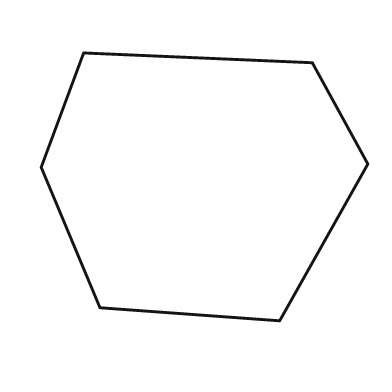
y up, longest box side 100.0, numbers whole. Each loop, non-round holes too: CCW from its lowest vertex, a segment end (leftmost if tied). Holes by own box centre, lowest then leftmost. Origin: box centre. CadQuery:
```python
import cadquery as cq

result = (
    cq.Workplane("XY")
    .moveTo(23.0, -41.0)
    .lineTo(50.0, 7.0)
    .lineTo(33.0, 38.0)
    .lineTo(-37.0, 41.0)
    .lineTo(-50.0, 6.0)
    .lineTo(-32.0, -37.0)
    .close()
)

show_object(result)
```